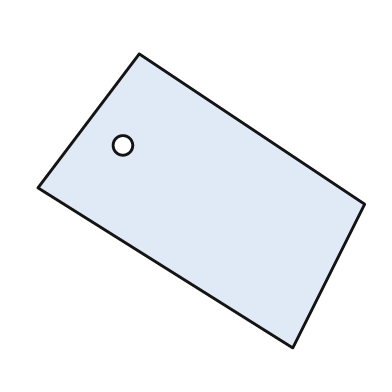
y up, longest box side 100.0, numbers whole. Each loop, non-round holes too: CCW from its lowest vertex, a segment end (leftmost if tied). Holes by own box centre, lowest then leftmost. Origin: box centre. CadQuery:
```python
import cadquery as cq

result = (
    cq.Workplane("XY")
    .moveTo(28.0, -45.0)
    .lineTo(50.0, -1.0)
    .lineTo(-19.0, 45.0)
    .lineTo(-50.0, 4.0)
    .close()
    .moveTo(-24.0, 17.0)
    .circle(3.0)
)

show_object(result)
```